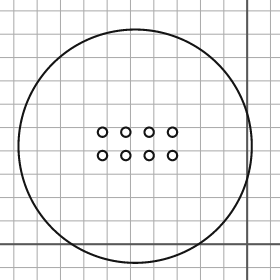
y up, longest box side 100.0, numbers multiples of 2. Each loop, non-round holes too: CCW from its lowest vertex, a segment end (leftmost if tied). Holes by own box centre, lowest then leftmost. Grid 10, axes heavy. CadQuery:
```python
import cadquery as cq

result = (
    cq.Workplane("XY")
    .moveTo(-48.0, 42.0)
    .circle(50.0)
    .moveTo(-62.0, 38.0)
    .circle(2.0)
    .moveTo(-52.0, 38.0)
    .circle(2.0)
    .moveTo(-42.0, 38.0)
    .circle(2.0)
    .moveTo(-32.0, 38.0)
    .circle(2.0)
    .moveTo(-62.0, 48.0)
    .circle(2.0)
    .moveTo(-52.0, 48.0)
    .circle(2.0)
    .moveTo(-42.0, 48.0)
    .circle(2.0)
    .moveTo(-32.0, 48.0)
    .circle(2.0)
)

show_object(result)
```